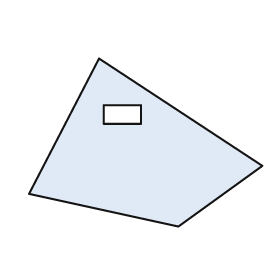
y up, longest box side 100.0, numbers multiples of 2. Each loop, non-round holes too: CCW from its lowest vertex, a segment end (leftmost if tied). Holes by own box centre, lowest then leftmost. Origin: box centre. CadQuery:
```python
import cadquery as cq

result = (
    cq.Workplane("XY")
    .moveTo(14.0, -36.0)
    .lineTo(50.0, -10.0)
    .lineTo(-20.0, 36.0)
    .lineTo(-50.0, -22.0)
    .close()
    .moveTo(-18.0, 8.0)
    .lineTo(-2.0, 8.0)
    .lineTo(-2.0, 16.0)
    .lineTo(-18.0, 16.0)
    .close()
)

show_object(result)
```